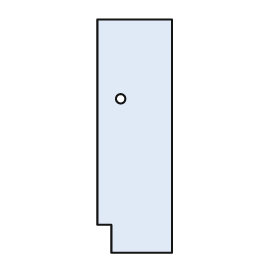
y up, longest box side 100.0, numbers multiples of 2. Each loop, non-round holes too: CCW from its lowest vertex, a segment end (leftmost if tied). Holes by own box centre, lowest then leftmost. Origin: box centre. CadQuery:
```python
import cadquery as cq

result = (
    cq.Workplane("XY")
    .moveTo(-10.0, -50.0)
    .lineTo(16.0, -50.0)
    .lineTo(16.0, 50.0)
    .lineTo(-16.0, 50.0)
    .lineTo(-16.0, -38.0)
    .lineTo(-10.0, -38.0)
    .close()
    .moveTo(-6.0, 16.0)
    .circle(2.0)
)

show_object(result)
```